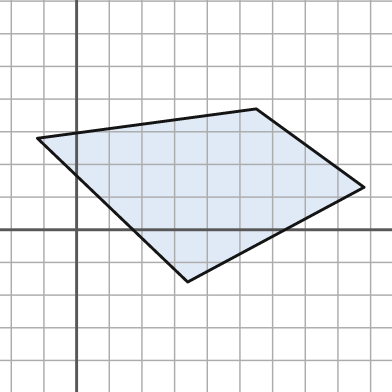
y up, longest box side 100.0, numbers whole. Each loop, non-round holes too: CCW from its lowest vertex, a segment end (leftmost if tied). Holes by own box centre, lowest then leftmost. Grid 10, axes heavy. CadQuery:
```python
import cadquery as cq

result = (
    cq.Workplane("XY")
    .moveTo(34.0, -16.0)
    .lineTo(88.0, 13.0)
    .lineTo(55.0, 37.0)
    .lineTo(-12.0, 28.0)
    .close()
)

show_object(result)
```